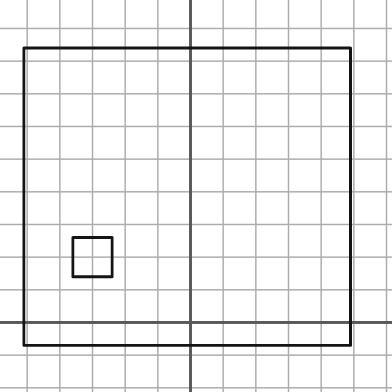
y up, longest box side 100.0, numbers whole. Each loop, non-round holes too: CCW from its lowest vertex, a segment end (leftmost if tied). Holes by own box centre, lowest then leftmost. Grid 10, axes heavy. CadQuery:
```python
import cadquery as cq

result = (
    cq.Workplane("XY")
    .moveTo(-51.0, -7.0)
    .lineTo(49.0, -7.0)
    .lineTo(49.0, 84.0)
    .lineTo(-51.0, 84.0)
    .close()
    .moveTo(-36.0, 14.0)
    .lineTo(-24.0, 14.0)
    .lineTo(-24.0, 26.0)
    .lineTo(-36.0, 26.0)
    .close()
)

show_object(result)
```